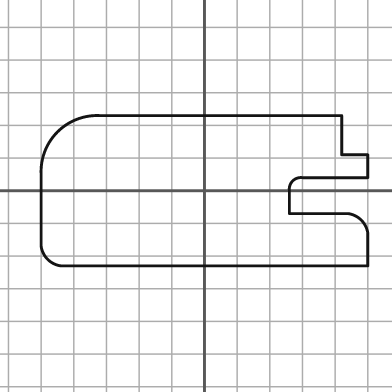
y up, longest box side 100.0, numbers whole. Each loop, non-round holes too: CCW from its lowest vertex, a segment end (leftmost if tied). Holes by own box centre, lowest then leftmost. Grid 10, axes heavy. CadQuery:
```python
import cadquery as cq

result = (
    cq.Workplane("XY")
    .moveTo(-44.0, -23.0)
    .lineTo(50.0, -23.0)
    .lineTo(50.0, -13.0)
    .threePointArc((48.0, -9.0), (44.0, -7.0))
    .lineTo(26.0, -7.0)
    .lineTo(26.0, 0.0)
    .threePointArc((27.0, 3.0), (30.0, 4.0))
    .lineTo(50.0, 4.0)
    .lineTo(50.0, 11.0)
    .lineTo(42.0, 11.0)
    .lineTo(42.0, 23.0)
    .lineTo(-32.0, 23.0)
    .threePointArc((-45.0, 18.0), (-50.0, 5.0))
    .lineTo(-50.0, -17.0)
    .threePointArc((-48.0, -21.0), (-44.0, -23.0))
    .close()
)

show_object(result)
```